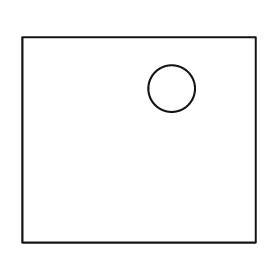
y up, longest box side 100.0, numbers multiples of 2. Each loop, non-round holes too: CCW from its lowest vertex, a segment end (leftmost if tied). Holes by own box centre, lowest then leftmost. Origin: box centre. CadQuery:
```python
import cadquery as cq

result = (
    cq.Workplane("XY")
    .moveTo(-50.0, -44.0)
    .lineTo(50.0, -44.0)
    .lineTo(50.0, 44.0)
    .lineTo(-50.0, 44.0)
    .close()
    .moveTo(14.0, 22.0)
    .circle(10.0)
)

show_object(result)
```